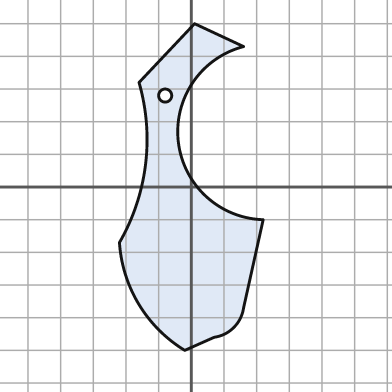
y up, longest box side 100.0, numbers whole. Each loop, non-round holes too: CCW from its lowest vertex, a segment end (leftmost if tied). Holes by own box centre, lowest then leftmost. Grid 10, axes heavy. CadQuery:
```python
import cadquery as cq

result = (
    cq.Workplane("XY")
    .moveTo(-2.0, -50.0)
    .lineTo(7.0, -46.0)
    .threePointArc((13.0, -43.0), (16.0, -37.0))
    .lineTo(22.0, -10.0)
    .threePointArc((-4.0, 14.0), (16.0, 43.0))
    .lineTo(1.0, 50.0)
    .lineTo(-16.0, 32.0)
    .threePointArc((-14.0, 7.0), (-22.0, -17.0))
    .threePointArc((-16.0, -36.0), (-2.0, -50.0))
    .close()
    .moveTo(-8.0, 28.0)
    .circle(2.0)
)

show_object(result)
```